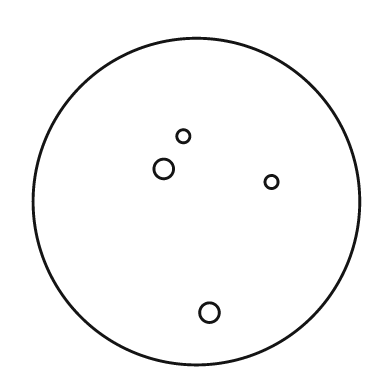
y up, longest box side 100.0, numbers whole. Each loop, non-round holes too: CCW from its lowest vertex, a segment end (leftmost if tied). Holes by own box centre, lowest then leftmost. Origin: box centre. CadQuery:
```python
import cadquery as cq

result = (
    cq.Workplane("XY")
    .moveTo(0.0, 0.0)
    .circle(50.0)
    .moveTo(4.0, -34.0)
    .circle(3.0)
    .moveTo(23.0, 6.0)
    .circle(2.0)
    .moveTo(-10.0, 10.0)
    .circle(3.0)
    .moveTo(-4.0, 20.0)
    .circle(2.0)
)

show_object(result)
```